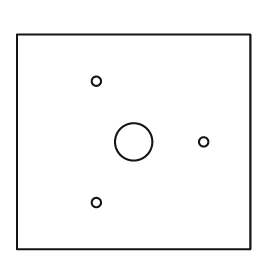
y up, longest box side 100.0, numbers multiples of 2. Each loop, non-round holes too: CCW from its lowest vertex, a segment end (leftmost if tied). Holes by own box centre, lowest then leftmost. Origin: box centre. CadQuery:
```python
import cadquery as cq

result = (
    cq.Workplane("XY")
    .moveTo(-50.0, -46.0)
    .lineTo(50.0, -46.0)
    .lineTo(50.0, 46.0)
    .lineTo(-50.0, 46.0)
    .close()
    .moveTo(-16.0, -26.0)
    .circle(2.0)
    .moveTo(0.0, 0.0)
    .circle(8.0)
    .moveTo(30.0, 0.0)
    .circle(2.0)
    .moveTo(-16.0, 26.0)
    .circle(2.0)
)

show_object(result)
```